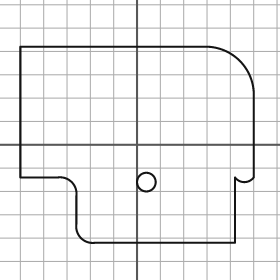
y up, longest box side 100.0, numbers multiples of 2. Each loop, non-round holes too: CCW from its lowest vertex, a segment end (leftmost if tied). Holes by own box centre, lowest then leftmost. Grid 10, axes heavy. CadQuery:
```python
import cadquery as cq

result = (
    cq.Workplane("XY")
    .moveTo(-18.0, -42.0)
    .lineTo(42.0, -42.0)
    .lineTo(42.0, -14.0)
    .threePointArc((46.0, -16.0), (50.0, -14.0))
    .lineTo(50.0, 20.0)
    .threePointArc((44.0, 36.0), (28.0, 42.0))
    .lineTo(-50.0, 42.0)
    .lineTo(-50.0, -14.0)
    .lineTo(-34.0, -14.0)
    .threePointArc((-28.0, -16.0), (-26.0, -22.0))
    .lineTo(-26.0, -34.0)
    .threePointArc((-24.0, -40.0), (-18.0, -42.0))
    .close()
    .moveTo(4.0, -16.0)
    .circle(4.0)
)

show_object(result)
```